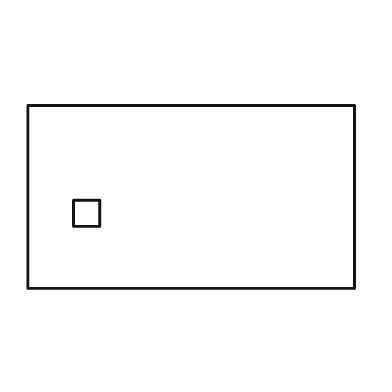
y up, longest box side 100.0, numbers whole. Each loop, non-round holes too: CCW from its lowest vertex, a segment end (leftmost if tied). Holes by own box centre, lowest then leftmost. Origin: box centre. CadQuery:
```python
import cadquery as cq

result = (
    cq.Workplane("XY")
    .moveTo(-50.0, -28.0)
    .lineTo(50.0, -28.0)
    .lineTo(50.0, 28.0)
    .lineTo(-50.0, 28.0)
    .close()
    .moveTo(-36.0, -9.0)
    .lineTo(-28.0, -9.0)
    .lineTo(-28.0, -1.0)
    .lineTo(-36.0, -1.0)
    .close()
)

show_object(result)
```